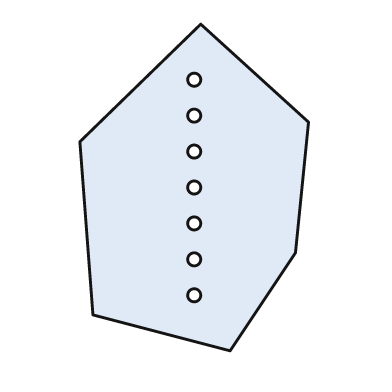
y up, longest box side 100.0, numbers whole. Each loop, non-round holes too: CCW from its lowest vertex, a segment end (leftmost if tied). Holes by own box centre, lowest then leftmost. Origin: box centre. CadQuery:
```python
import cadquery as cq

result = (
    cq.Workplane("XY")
    .moveTo(11.0, -50.0)
    .lineTo(31.0, -20.0)
    .lineTo(35.0, 20.0)
    .lineTo(2.0, 50.0)
    .lineTo(-35.0, 14.0)
    .lineTo(-31.0, -39.0)
    .close()
    .moveTo(0.0, -33.0)
    .circle(2.0)
    .moveTo(0.0, -22.0)
    .circle(2.0)
    .moveTo(0.0, -11.0)
    .circle(2.0)
    .moveTo(0.0, 0.0)
    .circle(2.0)
    .moveTo(0.0, 11.0)
    .circle(2.0)
    .moveTo(0.0, 22.0)
    .circle(2.0)
    .moveTo(0.0, 33.0)
    .circle(2.0)
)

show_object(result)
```